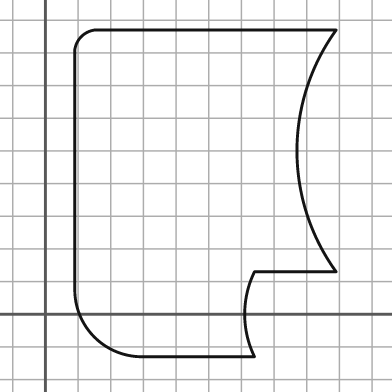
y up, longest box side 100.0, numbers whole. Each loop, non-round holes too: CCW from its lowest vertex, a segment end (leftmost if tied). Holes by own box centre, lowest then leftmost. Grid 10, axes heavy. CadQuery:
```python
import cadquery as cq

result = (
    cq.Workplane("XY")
    .moveTo(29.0, -13.0)
    .lineTo(64.0, -13.0)
    .threePointArc((61.0, 0.0), (64.0, 13.0))
    .lineTo(89.0, 13.0)
    .threePointArc((77.0, 50.0), (89.0, 87.0))
    .lineTo(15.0, 87.0)
    .threePointArc((11.0, 85.0), (9.0, 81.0))
    .lineTo(9.0, 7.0)
    .threePointArc((15.0, -7.0), (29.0, -13.0))
    .close()
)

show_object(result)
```